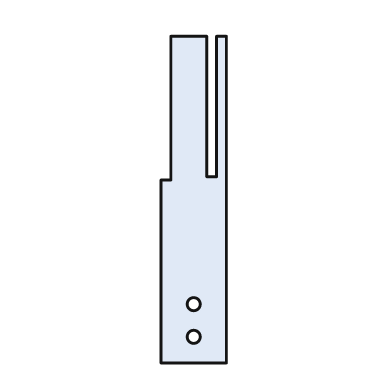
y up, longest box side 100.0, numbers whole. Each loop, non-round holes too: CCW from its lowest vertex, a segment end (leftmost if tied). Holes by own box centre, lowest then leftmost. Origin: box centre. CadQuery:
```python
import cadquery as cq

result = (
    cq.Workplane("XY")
    .moveTo(-10.0, -50.0)
    .lineTo(10.0, -50.0)
    .lineTo(10.0, 50.0)
    .lineTo(7.0, 50.0)
    .lineTo(7.0, 7.0)
    .lineTo(4.0, 7.0)
    .lineTo(4.0, 50.0)
    .lineTo(-7.0, 50.0)
    .lineTo(-7.0, 6.0)
    .lineTo(-10.0, 6.0)
    .close()
    .moveTo(0.0, -42.0)
    .circle(2.0)
    .moveTo(0.0, -32.0)
    .circle(2.0)
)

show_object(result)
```